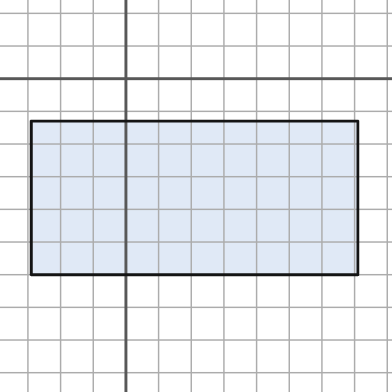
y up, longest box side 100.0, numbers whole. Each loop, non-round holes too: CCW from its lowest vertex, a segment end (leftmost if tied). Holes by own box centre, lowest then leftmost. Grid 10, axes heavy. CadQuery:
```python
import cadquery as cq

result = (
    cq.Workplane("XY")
    .moveTo(-29.0, -60.0)
    .lineTo(71.0, -60.0)
    .lineTo(71.0, -13.0)
    .lineTo(-29.0, -13.0)
    .close()
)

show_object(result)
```